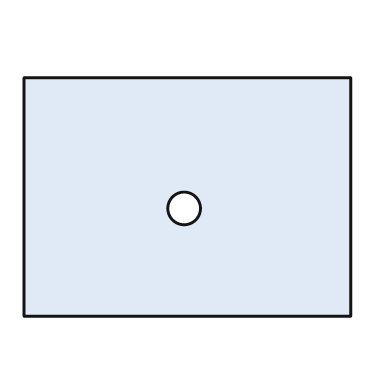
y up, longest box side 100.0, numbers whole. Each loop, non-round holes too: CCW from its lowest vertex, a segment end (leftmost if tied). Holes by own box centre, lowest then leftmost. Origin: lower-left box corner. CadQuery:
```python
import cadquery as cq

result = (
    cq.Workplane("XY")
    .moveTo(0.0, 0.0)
    .lineTo(100.0, 0.0)
    .lineTo(100.0, 73.0)
    .lineTo(0.0, 73.0)
    .close()
    .moveTo(49.0, 33.0)
    .circle(5.0)
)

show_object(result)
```